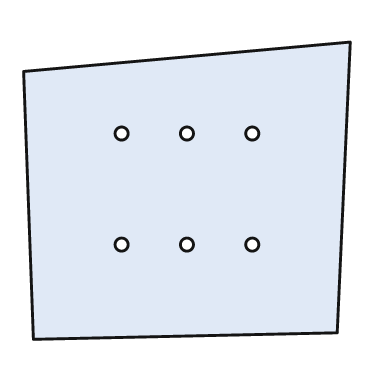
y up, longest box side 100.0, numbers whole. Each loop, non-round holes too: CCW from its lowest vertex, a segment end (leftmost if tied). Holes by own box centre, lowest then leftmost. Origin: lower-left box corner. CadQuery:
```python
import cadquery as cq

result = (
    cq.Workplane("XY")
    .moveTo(3.0, 0.0)
    .lineTo(96.0, 2.0)
    .lineTo(100.0, 91.0)
    .lineTo(0.0, 82.0)
    .close()
    .moveTo(30.0, 29.0)
    .circle(2.0)
    .moveTo(50.0, 29.0)
    .circle(2.0)
    .moveTo(70.0, 29.0)
    .circle(2.0)
    .moveTo(30.0, 63.0)
    .circle(2.0)
    .moveTo(50.0, 63.0)
    .circle(2.0)
    .moveTo(70.0, 63.0)
    .circle(2.0)
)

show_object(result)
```